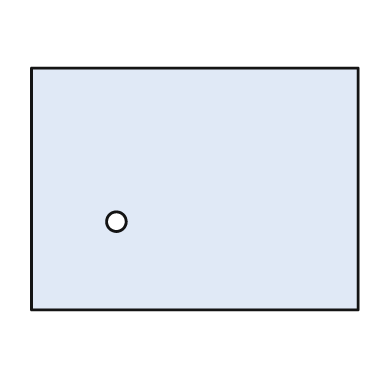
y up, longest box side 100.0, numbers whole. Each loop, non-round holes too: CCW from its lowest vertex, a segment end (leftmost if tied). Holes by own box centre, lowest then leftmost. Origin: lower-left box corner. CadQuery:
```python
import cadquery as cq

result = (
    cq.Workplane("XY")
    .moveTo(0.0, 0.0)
    .lineTo(100.0, 0.0)
    .lineTo(100.0, 74.0)
    .lineTo(0.0, 74.0)
    .close()
    .moveTo(26.0, 27.0)
    .circle(3.0)
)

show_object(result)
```